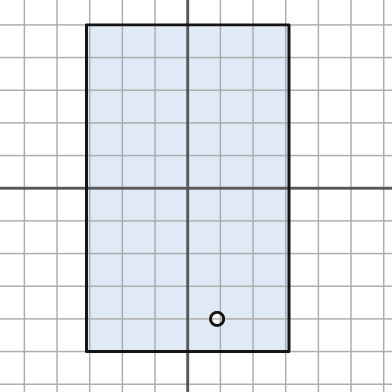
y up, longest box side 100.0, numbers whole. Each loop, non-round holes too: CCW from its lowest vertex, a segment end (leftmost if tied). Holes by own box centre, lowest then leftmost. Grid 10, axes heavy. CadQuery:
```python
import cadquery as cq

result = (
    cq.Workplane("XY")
    .moveTo(-31.0, -50.0)
    .lineTo(31.0, -50.0)
    .lineTo(31.0, 50.0)
    .lineTo(-31.0, 50.0)
    .close()
    .moveTo(9.0, -40.0)
    .circle(2.0)
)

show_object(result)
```